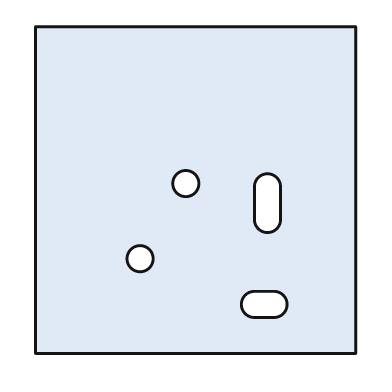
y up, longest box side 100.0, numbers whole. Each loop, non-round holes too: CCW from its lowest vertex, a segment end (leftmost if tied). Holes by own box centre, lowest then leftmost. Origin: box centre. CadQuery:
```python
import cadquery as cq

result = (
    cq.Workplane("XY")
    .moveTo(-49.0, -50.0)
    .lineTo(49.0, -50.0)
    .lineTo(49.0, 50.0)
    .lineTo(-49.0, 50.0)
    .close()
    .moveTo(18.0, -39.0)
    .lineTo(24.0, -39.0)
    .threePointArc((28.0, -35.0), (24.0, -31.0))
    .lineTo(18.0, -31.0)
    .threePointArc((14.0, -35.0), (18.0, -39.0))
    .close()
    .moveTo(-17.0, -21.0)
    .circle(4.0)
    .moveTo(18.0, -9.0)
    .threePointArc((22.0, -13.0), (26.0, -9.0))
    .lineTo(26.0, 1.0)
    .threePointArc((22.0, 5.0), (18.0, 1.0))
    .close()
    .moveTo(-3.0, 2.0)
    .circle(4.0)
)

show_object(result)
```